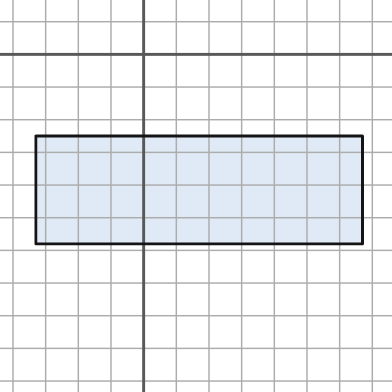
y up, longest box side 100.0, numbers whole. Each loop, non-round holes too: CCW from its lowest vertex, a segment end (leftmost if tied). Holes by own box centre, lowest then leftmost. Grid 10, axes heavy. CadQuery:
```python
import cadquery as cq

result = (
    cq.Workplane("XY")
    .moveTo(-33.0, -58.0)
    .lineTo(67.0, -58.0)
    .lineTo(67.0, -25.0)
    .lineTo(-33.0, -25.0)
    .close()
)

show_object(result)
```